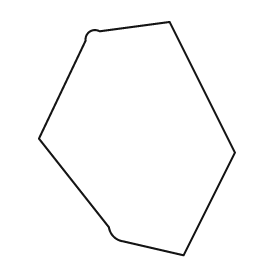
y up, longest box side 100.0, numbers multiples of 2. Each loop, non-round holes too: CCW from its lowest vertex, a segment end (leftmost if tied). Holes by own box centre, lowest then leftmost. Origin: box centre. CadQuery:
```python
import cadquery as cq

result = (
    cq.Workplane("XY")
    .moveTo(20.0, -50.0)
    .lineTo(42.0, -6.0)
    .lineTo(14.0, 50.0)
    .lineTo(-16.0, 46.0)
    .threePointArc((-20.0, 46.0), (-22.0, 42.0))
    .lineTo(-42.0, 0.0)
    .lineTo(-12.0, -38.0)
    .threePointArc((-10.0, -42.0), (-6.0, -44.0))
    .close()
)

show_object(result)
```